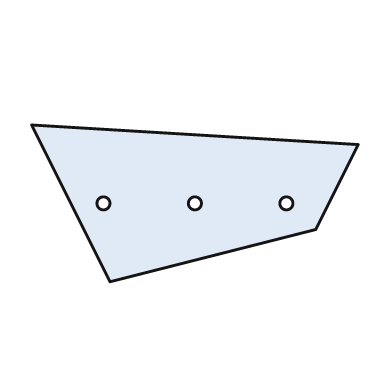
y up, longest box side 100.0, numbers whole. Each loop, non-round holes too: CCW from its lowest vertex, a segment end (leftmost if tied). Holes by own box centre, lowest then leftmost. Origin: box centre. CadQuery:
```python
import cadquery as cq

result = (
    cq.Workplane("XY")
    .moveTo(-26.0, -24.0)
    .lineTo(37.0, -8.0)
    .lineTo(50.0, 18.0)
    .lineTo(-50.0, 24.0)
    .close()
    .moveTo(-28.0, 0.0)
    .circle(2.0)
    .moveTo(0.0, 0.0)
    .circle(2.0)
    .moveTo(28.0, 0.0)
    .circle(2.0)
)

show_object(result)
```